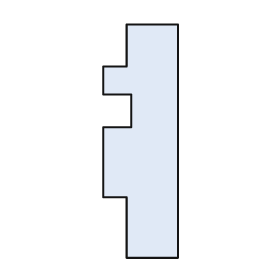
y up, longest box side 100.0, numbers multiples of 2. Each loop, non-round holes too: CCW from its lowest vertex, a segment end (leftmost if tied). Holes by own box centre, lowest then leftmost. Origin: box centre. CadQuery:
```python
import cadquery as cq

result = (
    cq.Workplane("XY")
    .moveTo(-6.0, -50.0)
    .lineTo(16.0, -50.0)
    .lineTo(16.0, 50.0)
    .lineTo(-6.0, 50.0)
    .lineTo(-6.0, 32.0)
    .lineTo(-16.0, 32.0)
    .lineTo(-16.0, 20.0)
    .lineTo(-4.0, 20.0)
    .lineTo(-4.0, 6.0)
    .lineTo(-16.0, 6.0)
    .lineTo(-16.0, -24.0)
    .lineTo(-6.0, -24.0)
    .close()
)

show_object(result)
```